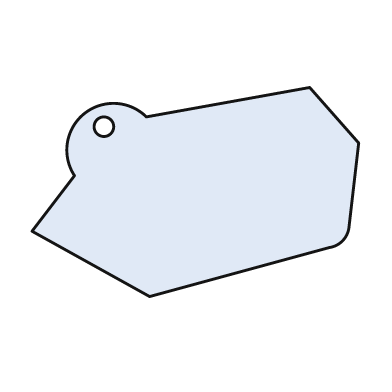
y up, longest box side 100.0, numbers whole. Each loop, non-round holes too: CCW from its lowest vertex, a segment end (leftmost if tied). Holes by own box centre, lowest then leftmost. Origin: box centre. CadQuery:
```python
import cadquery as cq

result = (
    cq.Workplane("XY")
    .moveTo(-14.0, -32.0)
    .lineTo(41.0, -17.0)
    .threePointArc((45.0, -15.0), (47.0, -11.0))
    .lineTo(50.0, 15.0)
    .lineTo(35.0, 32.0)
    .lineTo(-15.0, 23.0)
    .threePointArc((-34.0, 24.0), (-37.0, 5.0))
    .lineTo(-50.0, -12.0)
    .close()
    .moveTo(-28.0, 20.0)
    .circle(3.0)
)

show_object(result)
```